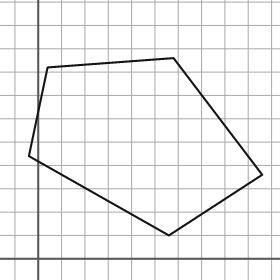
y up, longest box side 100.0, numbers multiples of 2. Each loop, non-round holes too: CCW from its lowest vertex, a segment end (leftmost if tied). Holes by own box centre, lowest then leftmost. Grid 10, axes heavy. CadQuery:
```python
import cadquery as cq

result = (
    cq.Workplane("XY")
    .moveTo(56.0, 10.0)
    .lineTo(96.0, 36.0)
    .lineTo(58.0, 86.0)
    .lineTo(4.0, 82.0)
    .lineTo(-4.0, 44.0)
    .close()
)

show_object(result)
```